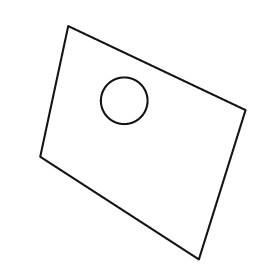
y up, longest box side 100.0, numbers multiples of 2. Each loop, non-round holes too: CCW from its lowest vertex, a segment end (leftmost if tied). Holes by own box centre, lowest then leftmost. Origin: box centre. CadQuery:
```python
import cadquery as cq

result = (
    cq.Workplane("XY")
    .moveTo(24.0, -50.0)
    .lineTo(44.0, 14.0)
    .lineTo(-32.0, 50.0)
    .lineTo(-44.0, -6.0)
    .close()
    .moveTo(-8.0, 18.0)
    .circle(10.0)
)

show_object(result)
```